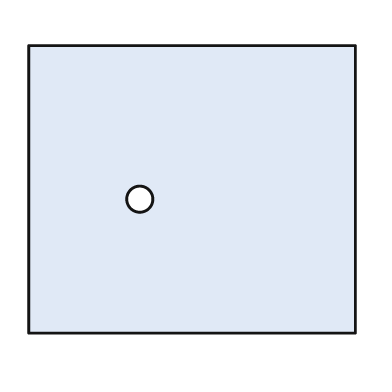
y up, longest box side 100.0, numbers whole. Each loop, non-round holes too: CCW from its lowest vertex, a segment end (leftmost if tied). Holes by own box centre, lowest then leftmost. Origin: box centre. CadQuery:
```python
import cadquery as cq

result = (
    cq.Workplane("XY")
    .moveTo(-50.0, -44.0)
    .lineTo(50.0, -44.0)
    .lineTo(50.0, 44.0)
    .lineTo(-50.0, 44.0)
    .close()
    .moveTo(-16.0, -3.0)
    .circle(4.0)
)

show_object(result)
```